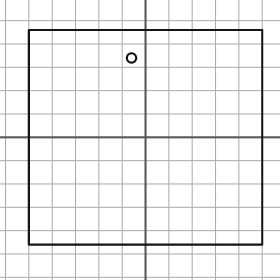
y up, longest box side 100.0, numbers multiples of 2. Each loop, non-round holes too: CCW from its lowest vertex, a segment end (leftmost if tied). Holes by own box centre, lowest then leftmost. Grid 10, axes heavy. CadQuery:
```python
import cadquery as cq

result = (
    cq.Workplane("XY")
    .moveTo(-50.0, -46.0)
    .lineTo(50.0, -46.0)
    .lineTo(50.0, 46.0)
    .lineTo(-50.0, 46.0)
    .close()
    .moveTo(-6.0, 34.0)
    .circle(2.0)
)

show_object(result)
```